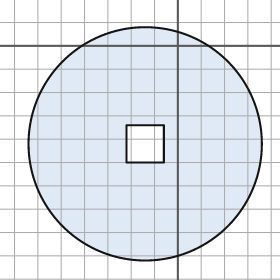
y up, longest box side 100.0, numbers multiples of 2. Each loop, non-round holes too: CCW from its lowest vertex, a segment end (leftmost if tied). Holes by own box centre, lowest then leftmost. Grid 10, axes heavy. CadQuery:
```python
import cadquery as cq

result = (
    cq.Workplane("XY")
    .moveTo(-14.0, -42.0)
    .circle(50.0)
    .moveTo(-22.0, -50.0)
    .lineTo(-6.0, -50.0)
    .lineTo(-6.0, -34.0)
    .lineTo(-22.0, -34.0)
    .close()
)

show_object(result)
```